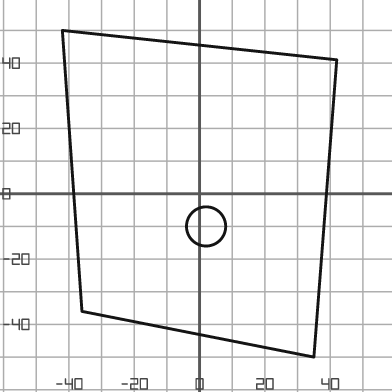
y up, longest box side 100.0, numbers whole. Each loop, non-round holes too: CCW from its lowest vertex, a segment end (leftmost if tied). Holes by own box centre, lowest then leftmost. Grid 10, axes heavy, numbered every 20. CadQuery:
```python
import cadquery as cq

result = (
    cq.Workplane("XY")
    .moveTo(35.0, -50.0)
    .lineTo(42.0, 41.0)
    .lineTo(-42.0, 50.0)
    .lineTo(-36.0, -36.0)
    .close()
    .moveTo(2.0, -10.0)
    .circle(6.0)
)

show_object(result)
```